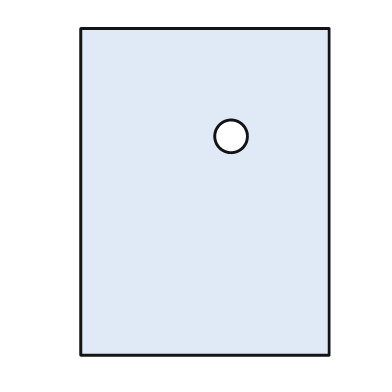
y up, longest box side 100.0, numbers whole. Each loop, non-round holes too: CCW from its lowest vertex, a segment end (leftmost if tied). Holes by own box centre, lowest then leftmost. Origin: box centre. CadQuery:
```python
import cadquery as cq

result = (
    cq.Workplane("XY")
    .moveTo(-38.0, -50.0)
    .lineTo(38.0, -50.0)
    .lineTo(38.0, 50.0)
    .lineTo(-38.0, 50.0)
    .close()
    .moveTo(8.0, 17.0)
    .circle(5.0)
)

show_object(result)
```